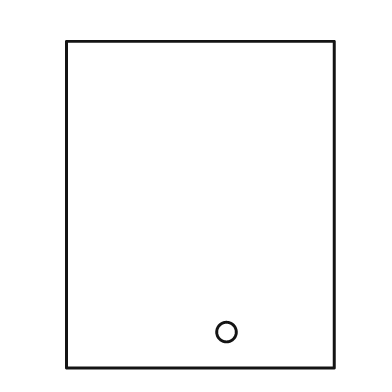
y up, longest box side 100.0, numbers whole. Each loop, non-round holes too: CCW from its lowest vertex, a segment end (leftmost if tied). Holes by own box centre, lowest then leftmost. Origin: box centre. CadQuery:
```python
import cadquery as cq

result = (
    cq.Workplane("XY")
    .moveTo(-41.0, -50.0)
    .lineTo(41.0, -50.0)
    .lineTo(41.0, 50.0)
    .lineTo(-41.0, 50.0)
    .close()
    .moveTo(8.0, -39.0)
    .circle(3.0)
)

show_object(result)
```